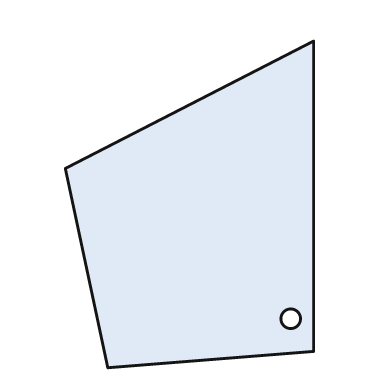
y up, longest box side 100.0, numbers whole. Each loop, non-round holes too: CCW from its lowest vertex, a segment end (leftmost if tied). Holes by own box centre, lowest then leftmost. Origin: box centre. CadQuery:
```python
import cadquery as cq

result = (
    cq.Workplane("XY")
    .moveTo(-25.0, -50.0)
    .lineTo(38.0, -45.0)
    .lineTo(38.0, 50.0)
    .lineTo(-38.0, 11.0)
    .close()
    .moveTo(31.0, -35.0)
    .circle(3.0)
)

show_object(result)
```